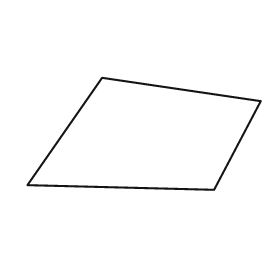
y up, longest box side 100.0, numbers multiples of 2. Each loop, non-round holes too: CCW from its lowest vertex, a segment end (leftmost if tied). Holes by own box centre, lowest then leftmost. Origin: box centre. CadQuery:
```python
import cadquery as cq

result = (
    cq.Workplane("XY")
    .moveTo(30.0, -24.0)
    .lineTo(50.0, 14.0)
    .lineTo(-18.0, 24.0)
    .lineTo(-50.0, -22.0)
    .close()
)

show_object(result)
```